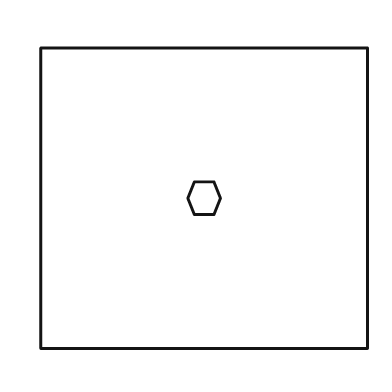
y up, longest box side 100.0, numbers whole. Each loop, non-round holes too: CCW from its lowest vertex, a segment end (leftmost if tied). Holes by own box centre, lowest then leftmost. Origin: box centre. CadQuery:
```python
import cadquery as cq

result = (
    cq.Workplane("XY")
    .moveTo(-50.0, -46.0)
    .lineTo(50.0, -46.0)
    .lineTo(50.0, 46.0)
    .lineTo(-50.0, 46.0)
    .close()
    .moveTo(-3.0, -5.0)
    .lineTo(3.0, -5.0)
    .lineTo(5.0, 0.0)
    .lineTo(3.0, 5.0)
    .lineTo(-3.0, 5.0)
    .lineTo(-5.0, 0.0)
    .close()
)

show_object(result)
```